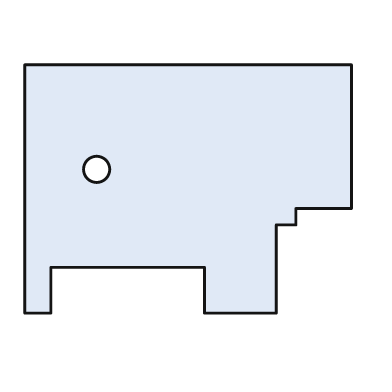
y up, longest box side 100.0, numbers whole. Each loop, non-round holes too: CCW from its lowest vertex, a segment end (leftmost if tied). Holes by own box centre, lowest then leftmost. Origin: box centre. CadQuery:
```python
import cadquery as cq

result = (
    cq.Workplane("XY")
    .moveTo(-50.0, -38.0)
    .lineTo(-42.0, -38.0)
    .lineTo(-42.0, -24.0)
    .lineTo(5.0, -24.0)
    .lineTo(5.0, -38.0)
    .lineTo(27.0, -38.0)
    .lineTo(27.0, -11.0)
    .lineTo(33.0, -11.0)
    .lineTo(33.0, -6.0)
    .lineTo(50.0, -6.0)
    .lineTo(50.0, 38.0)
    .lineTo(-50.0, 38.0)
    .close()
    .moveTo(-28.0, 6.0)
    .circle(4.0)
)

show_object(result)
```